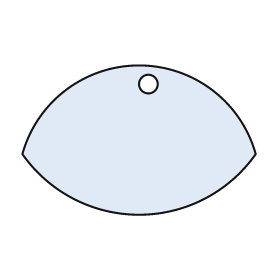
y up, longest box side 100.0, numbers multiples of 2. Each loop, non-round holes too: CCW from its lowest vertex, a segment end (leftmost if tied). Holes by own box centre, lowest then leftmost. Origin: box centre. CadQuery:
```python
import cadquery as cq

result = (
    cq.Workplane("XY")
    .moveTo(-50.0, -6.0)
    .threePointArc((0.0, -32.0), (50.0, -6.0))
    .threePointArc((0.0, 32.0), (-50.0, -6.0))
    .close()
    .moveTo(4.0, 24.0)
    .circle(4.0)
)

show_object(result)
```